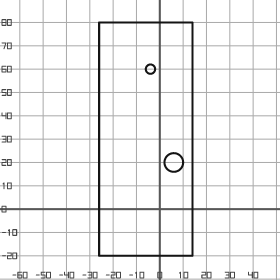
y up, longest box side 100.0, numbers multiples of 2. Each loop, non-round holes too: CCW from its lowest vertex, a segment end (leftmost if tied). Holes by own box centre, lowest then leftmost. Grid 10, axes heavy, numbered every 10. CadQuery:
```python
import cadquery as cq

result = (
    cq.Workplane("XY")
    .moveTo(-26.0, -20.0)
    .lineTo(14.0, -20.0)
    .lineTo(14.0, 80.0)
    .lineTo(-26.0, 80.0)
    .close()
    .moveTo(6.0, 20.0)
    .circle(4.0)
    .moveTo(-4.0, 60.0)
    .circle(2.0)
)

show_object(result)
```